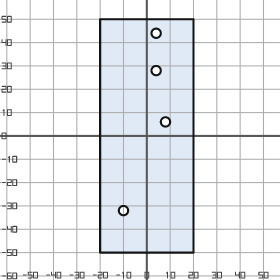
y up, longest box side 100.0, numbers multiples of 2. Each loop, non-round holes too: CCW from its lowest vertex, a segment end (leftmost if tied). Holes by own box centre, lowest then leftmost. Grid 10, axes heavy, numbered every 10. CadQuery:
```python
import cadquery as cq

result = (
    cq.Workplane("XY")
    .moveTo(-20.0, -50.0)
    .lineTo(20.0, -50.0)
    .lineTo(20.0, 50.0)
    .lineTo(-20.0, 50.0)
    .close()
    .moveTo(-10.0, -32.0)
    .circle(2.0)
    .moveTo(8.0, 6.0)
    .circle(2.0)
    .moveTo(4.0, 28.0)
    .circle(2.0)
    .moveTo(4.0, 44.0)
    .circle(2.0)
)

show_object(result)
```